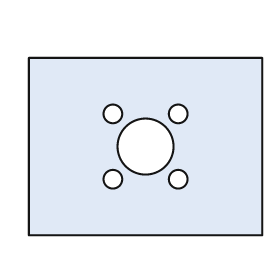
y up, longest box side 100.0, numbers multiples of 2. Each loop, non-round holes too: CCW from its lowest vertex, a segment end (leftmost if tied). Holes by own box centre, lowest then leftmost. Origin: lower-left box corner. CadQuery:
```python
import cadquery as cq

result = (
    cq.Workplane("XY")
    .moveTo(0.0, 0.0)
    .lineTo(100.0, 0.0)
    .lineTo(100.0, 76.0)
    .lineTo(0.0, 76.0)
    .close()
    .moveTo(36.0, 24.0)
    .circle(4.0)
    .moveTo(64.0, 24.0)
    .circle(4.0)
    .moveTo(50.0, 38.0)
    .circle(12.0)
    .moveTo(36.0, 52.0)
    .circle(4.0)
    .moveTo(64.0, 52.0)
    .circle(4.0)
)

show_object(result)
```